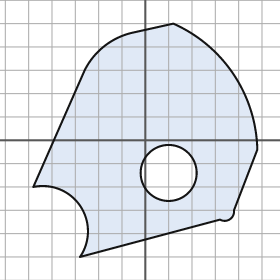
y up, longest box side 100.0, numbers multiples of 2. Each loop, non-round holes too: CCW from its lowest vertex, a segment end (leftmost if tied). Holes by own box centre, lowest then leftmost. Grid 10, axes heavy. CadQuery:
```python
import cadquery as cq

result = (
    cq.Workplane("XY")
    .moveTo(-28.0, -50.0)
    .lineTo(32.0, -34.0)
    .threePointArc((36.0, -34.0), (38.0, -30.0))
    .lineTo(48.0, -4.0)
    .threePointArc((38.0, 28.0), (12.0, 50.0))
    .lineTo(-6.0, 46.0)
    .threePointArc((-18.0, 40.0), (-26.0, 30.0))
    .lineTo(-48.0, -20.0)
    .threePointArc((-28.0, -28.0), (-28.0, -50.0))
    .close()
    .moveTo(10.0, -14.0)
    .circle(12.0)
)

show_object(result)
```